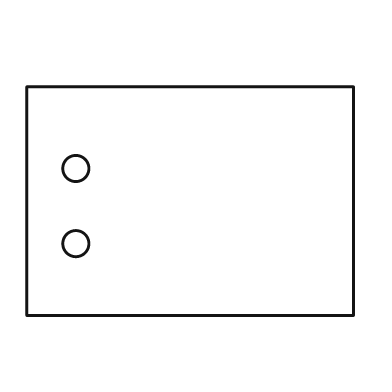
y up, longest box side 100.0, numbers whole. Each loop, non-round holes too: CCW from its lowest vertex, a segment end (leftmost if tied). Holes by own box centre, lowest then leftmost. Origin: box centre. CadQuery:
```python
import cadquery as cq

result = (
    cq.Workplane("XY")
    .moveTo(-50.0, -35.0)
    .lineTo(50.0, -35.0)
    .lineTo(50.0, 35.0)
    .lineTo(-50.0, 35.0)
    .close()
    .moveTo(-35.0, -13.0)
    .circle(4.0)
    .moveTo(-35.0, 10.0)
    .circle(4.0)
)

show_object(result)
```